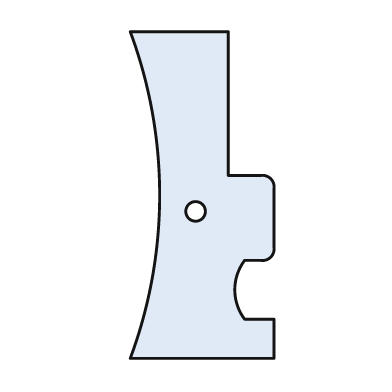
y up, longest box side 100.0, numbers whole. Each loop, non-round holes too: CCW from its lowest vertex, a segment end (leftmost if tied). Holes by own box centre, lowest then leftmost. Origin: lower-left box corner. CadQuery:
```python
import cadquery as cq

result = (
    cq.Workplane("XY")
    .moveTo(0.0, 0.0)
    .lineTo(44.0, 0.0)
    .lineTo(44.0, 12.0)
    .lineTo(35.0, 12.0)
    .threePointArc((32.0, 21.0), (35.0, 30.0))
    .lineTo(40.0, 30.0)
    .threePointArc((43.0, 31.0), (44.0, 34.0))
    .lineTo(44.0, 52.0)
    .threePointArc((43.0, 55.0), (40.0, 56.0))
    .lineTo(30.0, 56.0)
    .lineTo(30.0, 100.0)
    .lineTo(0.0, 100.0)
    .threePointArc((9.0, 50.0), (0.0, 0.0))
    .close()
    .moveTo(20.0, 45.0)
    .circle(3.0)
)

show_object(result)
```